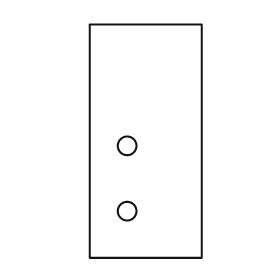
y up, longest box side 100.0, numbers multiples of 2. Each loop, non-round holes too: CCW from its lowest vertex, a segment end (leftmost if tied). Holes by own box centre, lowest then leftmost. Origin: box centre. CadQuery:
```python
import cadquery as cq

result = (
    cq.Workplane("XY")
    .moveTo(-24.0, -50.0)
    .lineTo(24.0, -50.0)
    .lineTo(24.0, 50.0)
    .lineTo(-24.0, 50.0)
    .close()
    .moveTo(-8.0, -30.0)
    .circle(4.0)
    .moveTo(-8.0, -2.0)
    .circle(4.0)
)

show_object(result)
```